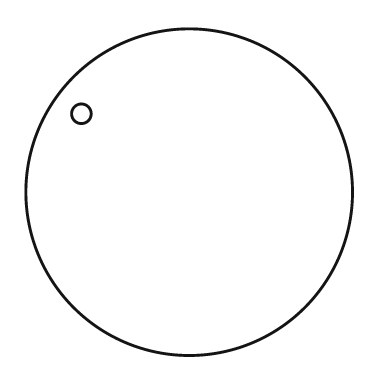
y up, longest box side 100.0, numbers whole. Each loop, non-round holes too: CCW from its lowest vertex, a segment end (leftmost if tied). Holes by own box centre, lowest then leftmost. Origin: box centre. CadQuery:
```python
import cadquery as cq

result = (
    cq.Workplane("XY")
    .moveTo(0.0, 0.0)
    .circle(50.0)
    .moveTo(-33.0, 24.0)
    .circle(3.0)
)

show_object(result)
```